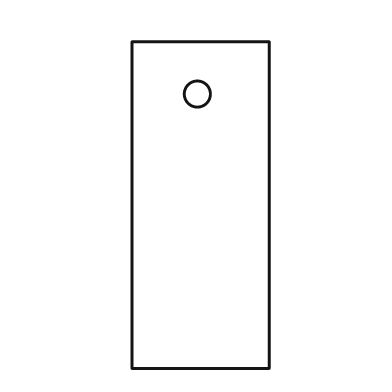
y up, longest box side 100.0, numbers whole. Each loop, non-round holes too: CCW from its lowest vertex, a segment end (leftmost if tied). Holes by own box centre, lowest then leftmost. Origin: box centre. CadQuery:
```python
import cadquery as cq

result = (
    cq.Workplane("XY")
    .moveTo(-21.0, -50.0)
    .lineTo(21.0, -50.0)
    .lineTo(21.0, 50.0)
    .lineTo(-21.0, 50.0)
    .close()
    .moveTo(-1.0, 34.0)
    .circle(4.0)
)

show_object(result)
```